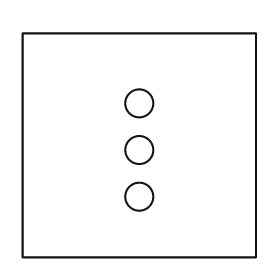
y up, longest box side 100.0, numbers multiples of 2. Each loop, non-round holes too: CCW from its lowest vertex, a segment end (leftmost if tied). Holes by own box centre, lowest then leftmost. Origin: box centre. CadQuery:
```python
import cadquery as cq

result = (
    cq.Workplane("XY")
    .moveTo(-50.0, -48.0)
    .lineTo(50.0, -48.0)
    .lineTo(50.0, 48.0)
    .lineTo(-50.0, 48.0)
    .close()
    .moveTo(0.0, -22.0)
    .circle(6.0)
    .moveTo(0.0, -2.0)
    .circle(6.0)
    .moveTo(0.0, 18.0)
    .circle(6.0)
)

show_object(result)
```